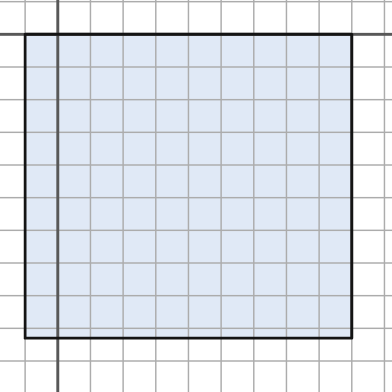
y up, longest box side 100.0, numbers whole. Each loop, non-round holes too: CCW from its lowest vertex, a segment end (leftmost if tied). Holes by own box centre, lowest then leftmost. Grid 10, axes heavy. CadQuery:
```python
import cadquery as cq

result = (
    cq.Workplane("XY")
    .moveTo(-10.0, -93.0)
    .lineTo(90.0, -93.0)
    .lineTo(90.0, 0.0)
    .lineTo(-10.0, 0.0)
    .close()
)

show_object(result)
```